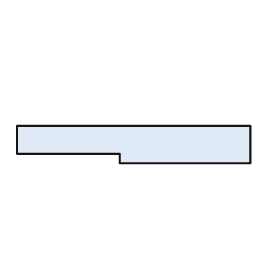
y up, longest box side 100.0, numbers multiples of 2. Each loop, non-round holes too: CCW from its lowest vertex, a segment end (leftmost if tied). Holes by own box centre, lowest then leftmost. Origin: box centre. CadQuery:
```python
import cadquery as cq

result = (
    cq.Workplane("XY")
    .moveTo(-6.0, -8.0)
    .lineTo(50.0, -8.0)
    .lineTo(50.0, 8.0)
    .lineTo(-50.0, 8.0)
    .lineTo(-50.0, -4.0)
    .lineTo(-6.0, -4.0)
    .close()
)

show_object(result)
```